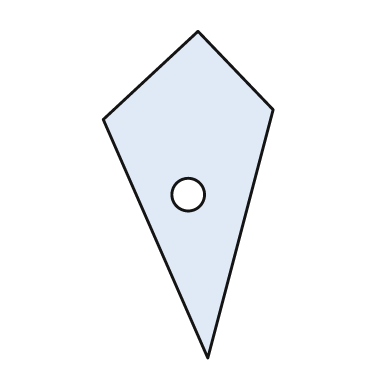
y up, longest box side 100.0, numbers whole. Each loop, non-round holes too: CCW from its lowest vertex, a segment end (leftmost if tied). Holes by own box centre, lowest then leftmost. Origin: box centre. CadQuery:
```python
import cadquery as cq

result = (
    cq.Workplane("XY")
    .moveTo(6.0, -50.0)
    .lineTo(26.0, 26.0)
    .lineTo(3.0, 50.0)
    .lineTo(-26.0, 23.0)
    .close()
    .moveTo(0.0, 0.0)
    .circle(5.0)
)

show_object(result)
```